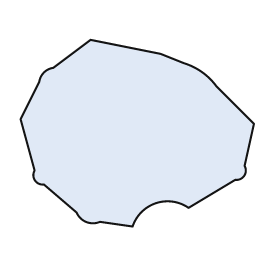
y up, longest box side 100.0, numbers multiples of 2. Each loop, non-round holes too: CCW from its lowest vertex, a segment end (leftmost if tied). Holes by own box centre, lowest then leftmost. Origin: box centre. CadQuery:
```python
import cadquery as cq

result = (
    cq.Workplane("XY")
    .moveTo(-2.0, -40.0)
    .threePointArc((8.0, -30.0), (22.0, -32.0))
    .lineTo(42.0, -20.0)
    .threePointArc((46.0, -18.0), (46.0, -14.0))
    .lineTo(50.0, 4.0)
    .lineTo(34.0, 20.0)
    .threePointArc((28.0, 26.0), (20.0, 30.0))
    .lineTo(10.0, 34.0)
    .lineTo(-20.0, 40.0)
    .lineTo(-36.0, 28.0)
    .threePointArc((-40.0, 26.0), (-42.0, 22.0))
    .lineTo(-50.0, 6.0)
    .lineTo(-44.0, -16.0)
    .threePointArc((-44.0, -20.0), (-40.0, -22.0))
    .lineTo(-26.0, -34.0)
    .threePointArc((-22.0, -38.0), (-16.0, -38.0))
    .close()
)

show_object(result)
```